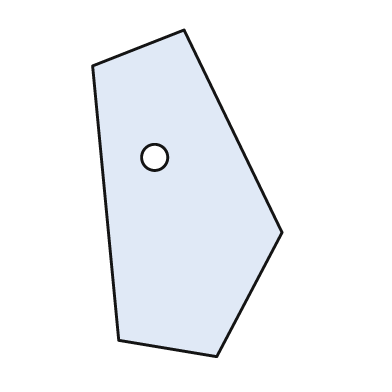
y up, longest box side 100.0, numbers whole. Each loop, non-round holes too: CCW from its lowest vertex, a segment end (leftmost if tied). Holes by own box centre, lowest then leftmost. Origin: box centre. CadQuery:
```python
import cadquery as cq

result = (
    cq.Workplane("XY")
    .moveTo(9.0, -50.0)
    .lineTo(29.0, -12.0)
    .lineTo(-1.0, 50.0)
    .lineTo(-29.0, 39.0)
    .lineTo(-21.0, -45.0)
    .close()
    .moveTo(-10.0, 11.0)
    .circle(4.0)
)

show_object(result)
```